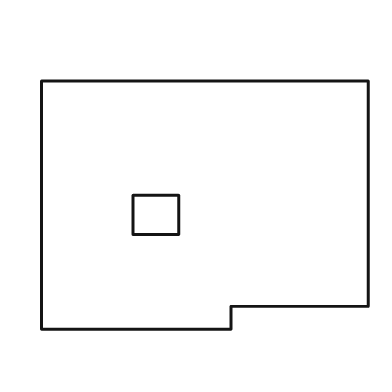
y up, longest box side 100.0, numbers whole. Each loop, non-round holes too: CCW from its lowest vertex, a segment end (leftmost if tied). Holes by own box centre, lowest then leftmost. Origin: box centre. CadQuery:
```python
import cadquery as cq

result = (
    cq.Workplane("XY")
    .moveTo(-50.0, -38.0)
    .lineTo(8.0, -38.0)
    .lineTo(8.0, -31.0)
    .lineTo(50.0, -31.0)
    .lineTo(50.0, 38.0)
    .lineTo(-50.0, 38.0)
    .close()
    .moveTo(-22.0, -9.0)
    .lineTo(-8.0, -9.0)
    .lineTo(-8.0, 3.0)
    .lineTo(-22.0, 3.0)
    .close()
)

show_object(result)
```